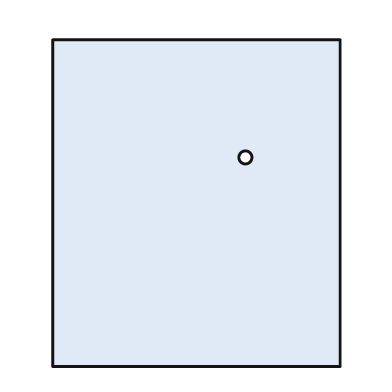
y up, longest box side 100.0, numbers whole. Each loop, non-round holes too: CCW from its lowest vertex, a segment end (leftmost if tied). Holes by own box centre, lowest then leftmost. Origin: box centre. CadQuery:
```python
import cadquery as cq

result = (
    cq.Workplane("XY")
    .moveTo(-44.0, -50.0)
    .lineTo(44.0, -50.0)
    .lineTo(44.0, 50.0)
    .lineTo(-44.0, 50.0)
    .close()
    .moveTo(15.0, 14.0)
    .circle(2.0)
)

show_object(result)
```